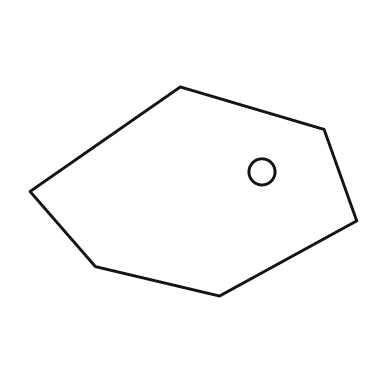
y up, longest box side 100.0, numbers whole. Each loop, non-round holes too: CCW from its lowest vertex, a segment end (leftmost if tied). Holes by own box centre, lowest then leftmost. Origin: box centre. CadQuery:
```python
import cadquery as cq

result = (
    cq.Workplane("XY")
    .moveTo(8.0, -32.0)
    .lineTo(50.0, -9.0)
    .lineTo(40.0, 19.0)
    .lineTo(-4.0, 32.0)
    .lineTo(-50.0, 0.0)
    .lineTo(-30.0, -23.0)
    .close()
    .moveTo(21.0, 6.0)
    .circle(4.0)
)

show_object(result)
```